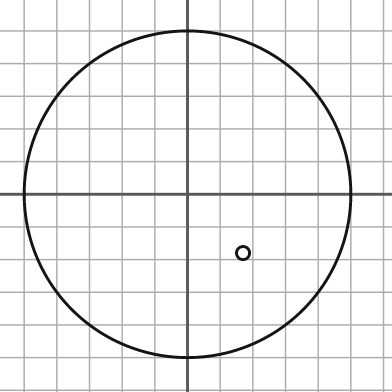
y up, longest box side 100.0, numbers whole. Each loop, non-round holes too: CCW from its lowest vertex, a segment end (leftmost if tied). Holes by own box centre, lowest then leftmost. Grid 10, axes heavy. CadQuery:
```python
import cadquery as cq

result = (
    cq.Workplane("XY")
    .moveTo(0.0, 0.0)
    .circle(50.0)
    .moveTo(17.0, -18.0)
    .circle(2.0)
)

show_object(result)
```